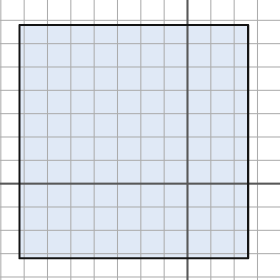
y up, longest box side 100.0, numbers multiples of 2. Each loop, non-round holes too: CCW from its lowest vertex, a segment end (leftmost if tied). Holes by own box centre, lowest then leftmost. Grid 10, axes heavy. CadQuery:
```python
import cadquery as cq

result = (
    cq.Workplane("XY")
    .moveTo(-72.0, -32.0)
    .lineTo(26.0, -32.0)
    .lineTo(26.0, 68.0)
    .lineTo(-72.0, 68.0)
    .close()
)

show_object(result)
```